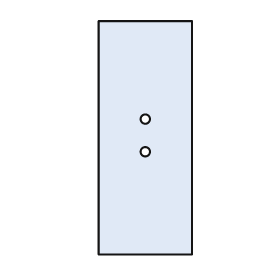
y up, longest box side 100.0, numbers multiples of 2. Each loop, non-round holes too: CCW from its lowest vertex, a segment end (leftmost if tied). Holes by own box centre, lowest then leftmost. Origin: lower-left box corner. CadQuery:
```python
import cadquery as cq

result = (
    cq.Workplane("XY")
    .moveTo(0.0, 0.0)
    .lineTo(40.0, 0.0)
    .lineTo(40.0, 100.0)
    .lineTo(0.0, 100.0)
    .close()
    .moveTo(20.0, 44.0)
    .circle(2.0)
    .moveTo(20.0, 58.0)
    .circle(2.0)
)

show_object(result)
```